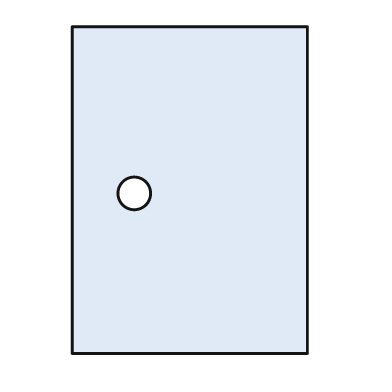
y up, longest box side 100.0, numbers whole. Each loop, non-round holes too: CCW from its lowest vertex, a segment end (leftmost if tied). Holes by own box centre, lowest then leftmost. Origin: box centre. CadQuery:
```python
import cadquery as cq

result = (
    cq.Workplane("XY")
    .moveTo(-36.0, -50.0)
    .lineTo(36.0, -50.0)
    .lineTo(36.0, 50.0)
    .lineTo(-36.0, 50.0)
    .close()
    .moveTo(-17.0, -1.0)
    .circle(5.0)
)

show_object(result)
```